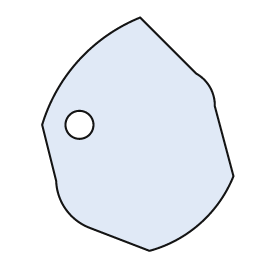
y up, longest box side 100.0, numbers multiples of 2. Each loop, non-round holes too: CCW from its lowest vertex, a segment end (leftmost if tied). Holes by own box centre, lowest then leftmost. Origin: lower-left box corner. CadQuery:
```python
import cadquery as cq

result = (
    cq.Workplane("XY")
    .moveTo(46.0, 0.0)
    .threePointArc((68.0, 12.0), (82.0, 32.0))
    .lineTo(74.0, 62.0)
    .threePointArc((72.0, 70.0), (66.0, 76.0))
    .lineTo(42.0, 100.0)
    .threePointArc((16.0, 82.0), (0.0, 54.0))
    .lineTo(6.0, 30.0)
    .threePointArc((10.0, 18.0), (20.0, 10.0))
    .close()
    .moveTo(16.0, 54.0)
    .circle(6.0)
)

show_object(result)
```